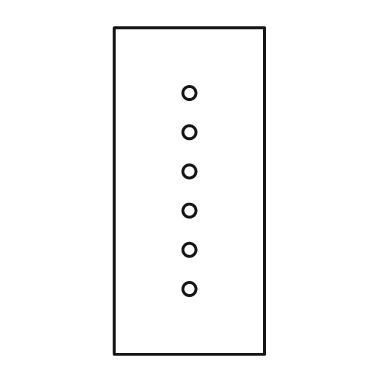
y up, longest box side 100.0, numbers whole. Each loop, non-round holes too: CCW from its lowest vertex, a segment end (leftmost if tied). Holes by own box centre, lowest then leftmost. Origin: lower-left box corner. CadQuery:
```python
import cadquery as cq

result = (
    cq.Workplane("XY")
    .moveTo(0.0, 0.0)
    .lineTo(46.0, 0.0)
    .lineTo(46.0, 100.0)
    .lineTo(0.0, 100.0)
    .close()
    .moveTo(23.0, 20.0)
    .circle(2.0)
    .moveTo(23.0, 32.0)
    .circle(2.0)
    .moveTo(23.0, 44.0)
    .circle(2.0)
    .moveTo(23.0, 56.0)
    .circle(2.0)
    .moveTo(23.0, 68.0)
    .circle(2.0)
    .moveTo(23.0, 80.0)
    .circle(2.0)
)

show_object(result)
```